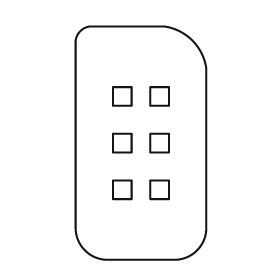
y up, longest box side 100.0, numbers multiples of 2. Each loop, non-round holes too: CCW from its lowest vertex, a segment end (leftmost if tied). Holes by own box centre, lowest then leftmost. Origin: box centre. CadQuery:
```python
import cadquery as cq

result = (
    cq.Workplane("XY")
    .moveTo(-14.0, -50.0)
    .lineTo(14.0, -50.0)
    .threePointArc((24.0, -46.0), (28.0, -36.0))
    .lineTo(28.0, 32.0)
    .threePointArc((22.0, 44.0), (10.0, 50.0))
    .lineTo(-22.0, 50.0)
    .threePointArc((-26.0, 48.0), (-28.0, 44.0))
    .lineTo(-28.0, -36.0)
    .threePointArc((-24.0, -46.0), (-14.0, -50.0))
    .close()
    .moveTo(-12.0, -24.0)
    .lineTo(-4.0, -24.0)
    .lineTo(-4.0, -16.0)
    .lineTo(-12.0, -16.0)
    .close()
    .moveTo(4.0, -24.0)
    .lineTo(12.0, -24.0)
    .lineTo(12.0, -16.0)
    .lineTo(4.0, -16.0)
    .close()
    .moveTo(-12.0, -4.0)
    .lineTo(-4.0, -4.0)
    .lineTo(-4.0, 4.0)
    .lineTo(-12.0, 4.0)
    .close()
    .moveTo(4.0, -4.0)
    .lineTo(12.0, -4.0)
    .lineTo(12.0, 4.0)
    .lineTo(4.0, 4.0)
    .close()
    .moveTo(-12.0, 16.0)
    .lineTo(-4.0, 16.0)
    .lineTo(-4.0, 24.0)
    .lineTo(-12.0, 24.0)
    .close()
    .moveTo(4.0, 16.0)
    .lineTo(12.0, 16.0)
    .lineTo(12.0, 24.0)
    .lineTo(4.0, 24.0)
    .close()
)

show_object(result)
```